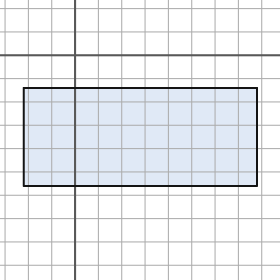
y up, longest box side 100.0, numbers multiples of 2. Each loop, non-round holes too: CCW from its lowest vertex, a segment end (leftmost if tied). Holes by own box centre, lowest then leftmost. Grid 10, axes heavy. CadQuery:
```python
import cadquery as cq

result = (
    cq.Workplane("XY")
    .moveTo(-22.0, -56.0)
    .lineTo(78.0, -56.0)
    .lineTo(78.0, -14.0)
    .lineTo(-22.0, -14.0)
    .close()
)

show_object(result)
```